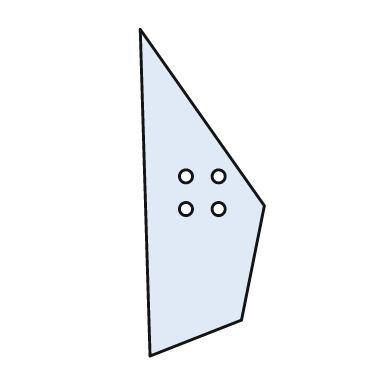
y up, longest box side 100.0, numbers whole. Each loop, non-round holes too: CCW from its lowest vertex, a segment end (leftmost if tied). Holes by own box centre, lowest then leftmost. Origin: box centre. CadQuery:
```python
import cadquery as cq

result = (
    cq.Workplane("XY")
    .moveTo(-16.0, -50.0)
    .lineTo(12.0, -39.0)
    .lineTo(19.0, -4.0)
    .lineTo(-19.0, 50.0)
    .close()
    .moveTo(-5.0, -5.0)
    .circle(2.0)
    .moveTo(5.0, -5.0)
    .circle(2.0)
    .moveTo(-5.0, 5.0)
    .circle(2.0)
    .moveTo(5.0, 5.0)
    .circle(2.0)
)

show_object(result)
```